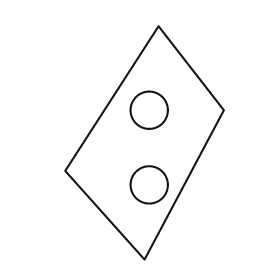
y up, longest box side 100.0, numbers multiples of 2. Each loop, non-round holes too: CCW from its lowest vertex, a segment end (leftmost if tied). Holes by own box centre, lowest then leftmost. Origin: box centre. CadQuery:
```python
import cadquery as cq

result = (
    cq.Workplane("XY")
    .moveTo(0.0, -50.0)
    .lineTo(34.0, 14.0)
    .lineTo(6.0, 50.0)
    .lineTo(-34.0, -12.0)
    .close()
    .moveTo(2.0, -18.0)
    .circle(8.0)
    .moveTo(2.0, 14.0)
    .circle(8.0)
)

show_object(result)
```